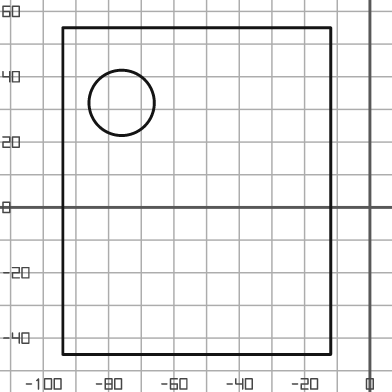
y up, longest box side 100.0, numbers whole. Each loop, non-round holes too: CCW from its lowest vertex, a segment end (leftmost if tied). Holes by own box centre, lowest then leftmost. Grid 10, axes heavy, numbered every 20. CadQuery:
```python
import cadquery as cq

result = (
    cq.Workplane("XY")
    .moveTo(-94.0, -45.0)
    .lineTo(-12.0, -45.0)
    .lineTo(-12.0, 55.0)
    .lineTo(-94.0, 55.0)
    .close()
    .moveTo(-76.0, 32.0)
    .circle(10.0)
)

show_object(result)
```